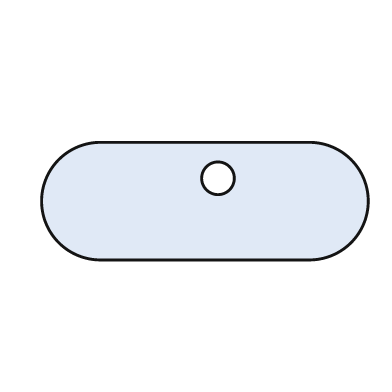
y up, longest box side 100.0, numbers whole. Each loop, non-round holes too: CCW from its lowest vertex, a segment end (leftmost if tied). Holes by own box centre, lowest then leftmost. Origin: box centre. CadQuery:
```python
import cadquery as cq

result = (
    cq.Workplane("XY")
    .moveTo(-32.0, -18.0)
    .lineTo(32.0, -18.0)
    .threePointArc((50.0, 0.0), (32.0, 18.0))
    .lineTo(-32.0, 18.0)
    .threePointArc((-50.0, 0.0), (-32.0, -18.0))
    .close()
    .moveTo(4.0, 7.0)
    .circle(5.0)
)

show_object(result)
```